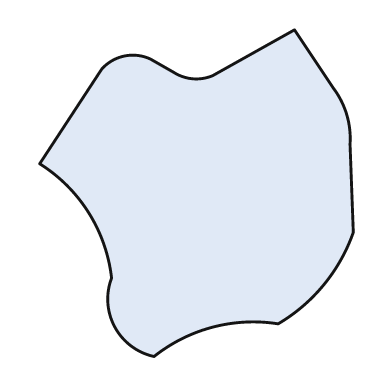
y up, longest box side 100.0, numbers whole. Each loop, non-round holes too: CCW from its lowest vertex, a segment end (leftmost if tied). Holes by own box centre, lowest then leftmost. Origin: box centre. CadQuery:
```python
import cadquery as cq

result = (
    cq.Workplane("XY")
    .moveTo(-13.0, -50.0)
    .threePointArc((5.0, -41.0), (25.0, -40.0))
    .threePointArc((39.0, -28.0), (48.0, -12.0))
    .lineTo(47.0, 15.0)
    .threePointArc((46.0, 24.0), (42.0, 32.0))
    .lineTo(30.0, 50.0)
    .lineTo(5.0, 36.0)
    .threePointArc((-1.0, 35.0), (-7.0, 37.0))
    .lineTo(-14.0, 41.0)
    .threePointArc((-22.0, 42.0), (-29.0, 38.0))
    .lineTo(-48.0, 9.0)
    .threePointArc((-33.0, -6.0), (-26.0, -26.0))
    .threePointArc((-25.0, -41.0), (-13.0, -50.0))
    .close()
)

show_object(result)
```